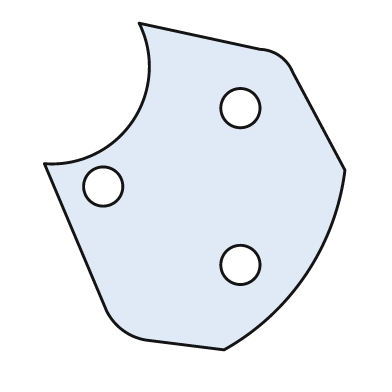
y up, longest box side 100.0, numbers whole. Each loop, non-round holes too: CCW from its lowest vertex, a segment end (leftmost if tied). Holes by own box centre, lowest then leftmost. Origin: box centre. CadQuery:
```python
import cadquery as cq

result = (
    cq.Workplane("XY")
    .moveTo(9.0, -50.0)
    .threePointArc((34.0, -27.0), (46.0, 5.0))
    .lineTo(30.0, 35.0)
    .threePointArc((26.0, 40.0), (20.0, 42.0))
    .lineTo(-17.0, 50.0)
    .threePointArc((-19.0, 20.0), (-46.0, 7.0))
    .lineTo(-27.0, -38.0)
    .threePointArc((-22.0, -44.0), (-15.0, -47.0))
    .close()
    .moveTo(14.0, -24.0)
    .circle(6.0)
    .moveTo(-28.0, 0.0)
    .circle(6.0)
    .moveTo(14.0, 24.0)
    .circle(6.0)
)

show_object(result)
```